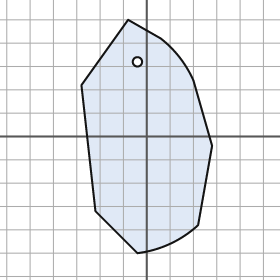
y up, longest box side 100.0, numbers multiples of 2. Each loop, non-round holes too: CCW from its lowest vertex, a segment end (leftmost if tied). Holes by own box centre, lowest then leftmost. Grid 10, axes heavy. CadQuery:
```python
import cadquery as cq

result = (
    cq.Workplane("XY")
    .moveTo(-4.0, -50.0)
    .threePointArc((10.0, -46.0), (22.0, -38.0))
    .lineTo(28.0, -4.0)
    .lineTo(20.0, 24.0)
    .threePointArc((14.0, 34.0), (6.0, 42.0))
    .lineTo(-8.0, 50.0)
    .lineTo(-28.0, 22.0)
    .lineTo(-22.0, -32.0)
    .close()
    .moveTo(-4.0, 32.0)
    .circle(2.0)
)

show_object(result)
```